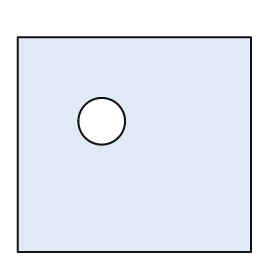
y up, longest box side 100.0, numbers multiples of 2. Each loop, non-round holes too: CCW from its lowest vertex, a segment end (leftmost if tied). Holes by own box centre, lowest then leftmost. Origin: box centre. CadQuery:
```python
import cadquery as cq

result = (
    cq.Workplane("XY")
    .moveTo(-50.0, -46.0)
    .lineTo(50.0, -46.0)
    .lineTo(50.0, 46.0)
    .lineTo(-50.0, 46.0)
    .close()
    .moveTo(-14.0, 10.0)
    .circle(10.0)
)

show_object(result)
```